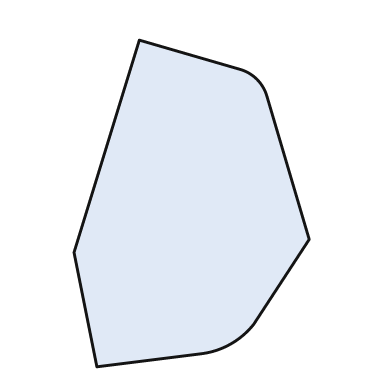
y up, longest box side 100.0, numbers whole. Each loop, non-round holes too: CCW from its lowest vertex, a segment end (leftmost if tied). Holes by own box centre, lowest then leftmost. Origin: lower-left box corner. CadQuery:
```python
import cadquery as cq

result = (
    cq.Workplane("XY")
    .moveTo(7.0, 0.0)
    .lineTo(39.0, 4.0)
    .threePointArc((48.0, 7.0), (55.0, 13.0))
    .lineTo(72.0, 39.0)
    .lineTo(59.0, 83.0)
    .threePointArc((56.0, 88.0), (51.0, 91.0))
    .lineTo(20.0, 100.0)
    .lineTo(0.0, 35.0)
    .close()
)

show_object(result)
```